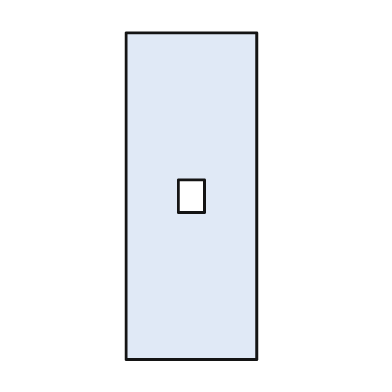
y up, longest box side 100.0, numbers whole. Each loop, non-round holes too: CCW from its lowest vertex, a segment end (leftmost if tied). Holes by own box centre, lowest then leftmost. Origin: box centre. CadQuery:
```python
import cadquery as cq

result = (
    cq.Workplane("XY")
    .moveTo(-20.0, -50.0)
    .lineTo(20.0, -50.0)
    .lineTo(20.0, 50.0)
    .lineTo(-20.0, 50.0)
    .close()
    .moveTo(-4.0, -5.0)
    .lineTo(4.0, -5.0)
    .lineTo(4.0, 5.0)
    .lineTo(-4.0, 5.0)
    .close()
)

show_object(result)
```